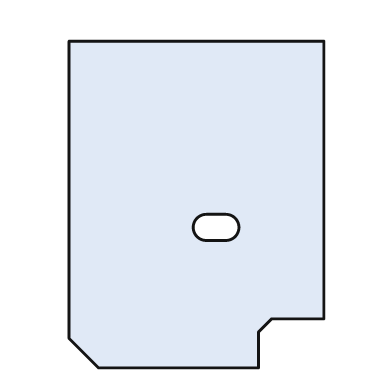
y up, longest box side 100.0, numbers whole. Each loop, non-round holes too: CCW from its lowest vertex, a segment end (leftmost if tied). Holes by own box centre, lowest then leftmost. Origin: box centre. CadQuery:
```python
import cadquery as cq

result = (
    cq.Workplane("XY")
    .moveTo(-30.0, -50.0)
    .lineTo(19.0, -50.0)
    .lineTo(19.0, -39.0)
    .lineTo(23.0, -35.0)
    .lineTo(39.0, -35.0)
    .lineTo(39.0, 50.0)
    .lineTo(-39.0, 50.0)
    .lineTo(-39.0, -41.0)
    .close()
    .moveTo(3.0, -11.0)
    .lineTo(9.0, -11.0)
    .threePointArc((13.0, -7.0), (9.0, -3.0))
    .lineTo(3.0, -3.0)
    .threePointArc((-1.0, -7.0), (3.0, -11.0))
    .close()
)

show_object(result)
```